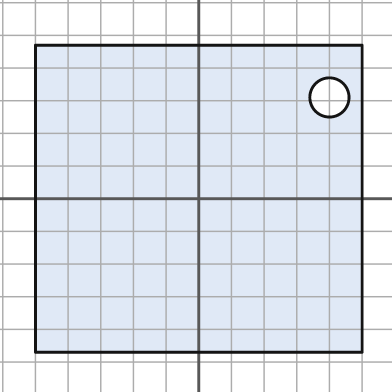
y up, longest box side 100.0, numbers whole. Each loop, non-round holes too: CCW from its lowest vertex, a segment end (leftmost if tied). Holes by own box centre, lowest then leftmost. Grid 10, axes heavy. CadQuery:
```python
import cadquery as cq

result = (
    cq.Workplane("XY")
    .moveTo(-50.0, -47.0)
    .lineTo(50.0, -47.0)
    .lineTo(50.0, 47.0)
    .lineTo(-50.0, 47.0)
    .close()
    .moveTo(40.0, 31.0)
    .circle(6.0)
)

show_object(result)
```